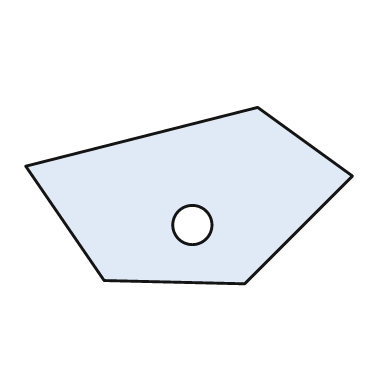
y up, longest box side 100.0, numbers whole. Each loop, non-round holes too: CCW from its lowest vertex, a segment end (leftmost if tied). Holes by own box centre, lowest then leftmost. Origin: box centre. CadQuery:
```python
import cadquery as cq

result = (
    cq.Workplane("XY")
    .moveTo(17.0, -27.0)
    .lineTo(50.0, 6.0)
    .lineTo(21.0, 27.0)
    .lineTo(-50.0, 9.0)
    .lineTo(-26.0, -26.0)
    .close()
    .moveTo(1.0, -9.0)
    .circle(6.0)
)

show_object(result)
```